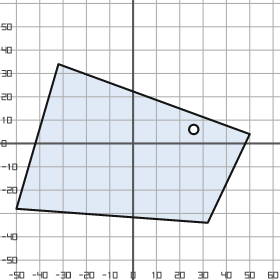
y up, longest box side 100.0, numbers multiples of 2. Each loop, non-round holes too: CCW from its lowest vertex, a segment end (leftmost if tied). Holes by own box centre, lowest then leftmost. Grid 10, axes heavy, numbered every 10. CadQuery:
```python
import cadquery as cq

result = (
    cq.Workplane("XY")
    .moveTo(32.0, -34.0)
    .lineTo(50.0, 4.0)
    .lineTo(-32.0, 34.0)
    .lineTo(-50.0, -28.0)
    .close()
    .moveTo(26.0, 6.0)
    .circle(2.0)
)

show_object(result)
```